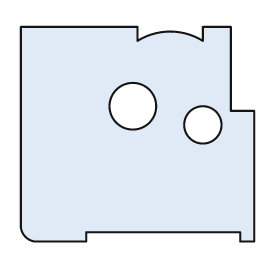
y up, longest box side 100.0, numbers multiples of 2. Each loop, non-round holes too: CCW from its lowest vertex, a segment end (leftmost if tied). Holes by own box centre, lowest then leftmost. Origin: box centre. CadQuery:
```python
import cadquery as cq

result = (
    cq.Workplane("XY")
    .moveTo(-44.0, -46.0)
    .lineTo(-22.0, -46.0)
    .lineTo(-22.0, -42.0)
    .lineTo(44.0, -42.0)
    .lineTo(44.0, -46.0)
    .lineTo(50.0, -46.0)
    .lineTo(50.0, 10.0)
    .lineTo(40.0, 10.0)
    .lineTo(40.0, 46.0)
    .lineTo(28.0, 46.0)
    .lineTo(28.0, 40.0)
    .threePointArc((14.0, 44.0), (0.0, 40.0))
    .lineTo(0.0, 46.0)
    .lineTo(-50.0, 46.0)
    .lineTo(-50.0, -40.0)
    .threePointArc((-48.0, -44.0), (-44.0, -46.0))
    .close()
    .moveTo(28.0, 4.0)
    .circle(8.0)
    .moveTo(-2.0, 12.0)
    .circle(10.0)
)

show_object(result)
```